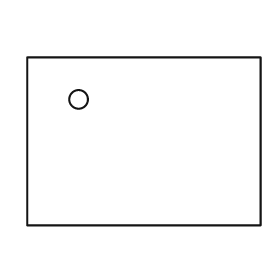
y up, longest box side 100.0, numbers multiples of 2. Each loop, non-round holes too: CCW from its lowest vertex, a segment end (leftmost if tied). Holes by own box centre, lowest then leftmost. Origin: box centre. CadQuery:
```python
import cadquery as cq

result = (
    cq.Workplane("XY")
    .moveTo(-50.0, -36.0)
    .lineTo(50.0, -36.0)
    .lineTo(50.0, 36.0)
    .lineTo(-50.0, 36.0)
    .close()
    .moveTo(-28.0, 18.0)
    .circle(4.0)
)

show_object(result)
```